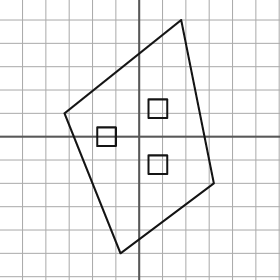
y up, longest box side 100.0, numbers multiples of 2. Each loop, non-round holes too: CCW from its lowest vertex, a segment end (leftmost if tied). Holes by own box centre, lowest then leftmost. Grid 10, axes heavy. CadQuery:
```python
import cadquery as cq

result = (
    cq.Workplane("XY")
    .moveTo(-8.0, -50.0)
    .lineTo(32.0, -20.0)
    .lineTo(18.0, 50.0)
    .lineTo(-32.0, 10.0)
    .close()
    .moveTo(4.0, -16.0)
    .lineTo(12.0, -16.0)
    .lineTo(12.0, -8.0)
    .lineTo(4.0, -8.0)
    .close()
    .moveTo(-18.0, -4.0)
    .lineTo(-10.0, -4.0)
    .lineTo(-10.0, 4.0)
    .lineTo(-18.0, 4.0)
    .close()
    .moveTo(4.0, 8.0)
    .lineTo(12.0, 8.0)
    .lineTo(12.0, 16.0)
    .lineTo(4.0, 16.0)
    .close()
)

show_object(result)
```